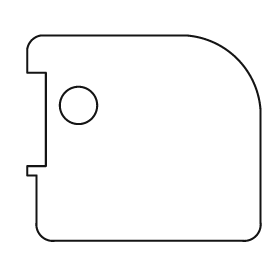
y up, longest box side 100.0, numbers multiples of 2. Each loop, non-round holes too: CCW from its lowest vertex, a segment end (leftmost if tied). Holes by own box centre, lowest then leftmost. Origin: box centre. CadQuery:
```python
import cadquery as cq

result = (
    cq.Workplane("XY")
    .moveTo(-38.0, -44.0)
    .lineTo(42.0, -44.0)
    .threePointArc((48.0, -42.0), (50.0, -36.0))
    .lineTo(50.0, 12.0)
    .threePointArc((40.0, 34.0), (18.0, 44.0))
    .lineTo(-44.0, 44.0)
    .threePointArc((-48.0, 42.0), (-50.0, 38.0))
    .lineTo(-50.0, 28.0)
    .lineTo(-42.0, 28.0)
    .lineTo(-42.0, -12.0)
    .lineTo(-50.0, -12.0)
    .lineTo(-50.0, -16.0)
    .lineTo(-46.0, -16.0)
    .lineTo(-46.0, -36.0)
    .threePointArc((-44.0, -42.0), (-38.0, -44.0))
    .close()
    .moveTo(-28.0, 14.0)
    .circle(8.0)
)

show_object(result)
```